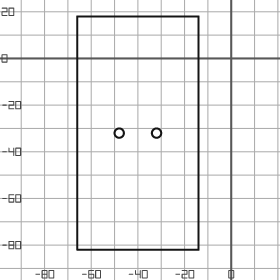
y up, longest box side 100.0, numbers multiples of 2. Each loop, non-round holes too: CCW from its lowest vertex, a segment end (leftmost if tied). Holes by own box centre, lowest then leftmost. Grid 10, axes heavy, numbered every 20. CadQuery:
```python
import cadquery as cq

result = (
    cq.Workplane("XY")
    .moveTo(-66.0, -82.0)
    .lineTo(-14.0, -82.0)
    .lineTo(-14.0, 18.0)
    .lineTo(-66.0, 18.0)
    .close()
    .moveTo(-48.0, -32.0)
    .circle(2.0)
    .moveTo(-32.0, -32.0)
    .circle(2.0)
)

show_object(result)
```